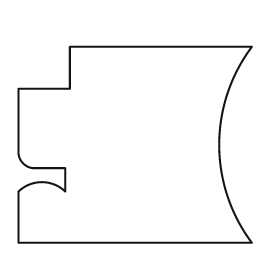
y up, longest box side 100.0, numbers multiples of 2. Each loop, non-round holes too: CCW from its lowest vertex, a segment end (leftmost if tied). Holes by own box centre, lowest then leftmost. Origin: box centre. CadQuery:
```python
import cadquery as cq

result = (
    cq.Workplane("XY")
    .moveTo(-50.0, -42.0)
    .lineTo(50.0, -42.0)
    .threePointArc((36.0, 0.0), (50.0, 42.0))
    .lineTo(-28.0, 42.0)
    .lineTo(-28.0, 24.0)
    .lineTo(-50.0, 24.0)
    .lineTo(-50.0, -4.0)
    .threePointArc((-48.0, -8.0), (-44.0, -10.0))
    .lineTo(-30.0, -10.0)
    .lineTo(-30.0, -20.0)
    .threePointArc((-40.0, -16.0), (-50.0, -20.0))
    .close()
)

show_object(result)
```